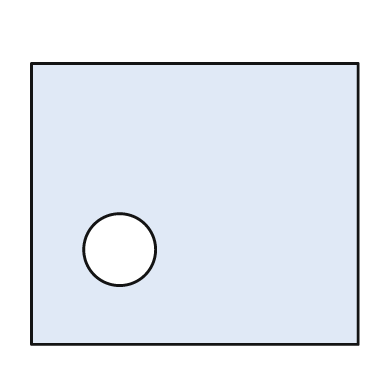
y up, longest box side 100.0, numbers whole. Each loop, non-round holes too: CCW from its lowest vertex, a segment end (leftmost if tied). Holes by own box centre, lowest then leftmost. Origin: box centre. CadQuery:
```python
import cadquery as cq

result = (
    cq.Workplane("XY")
    .moveTo(-50.0, -43.0)
    .lineTo(50.0, -43.0)
    .lineTo(50.0, 43.0)
    .lineTo(-50.0, 43.0)
    .close()
    .moveTo(-23.0, -14.0)
    .circle(11.0)
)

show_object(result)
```